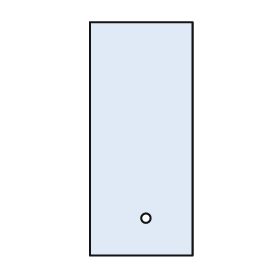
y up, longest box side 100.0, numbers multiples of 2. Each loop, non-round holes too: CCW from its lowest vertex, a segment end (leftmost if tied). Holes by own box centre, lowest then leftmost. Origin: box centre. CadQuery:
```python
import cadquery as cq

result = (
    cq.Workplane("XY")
    .moveTo(-22.0, -50.0)
    .lineTo(22.0, -50.0)
    .lineTo(22.0, 50.0)
    .lineTo(-22.0, 50.0)
    .close()
    .moveTo(2.0, -34.0)
    .circle(2.0)
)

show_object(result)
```